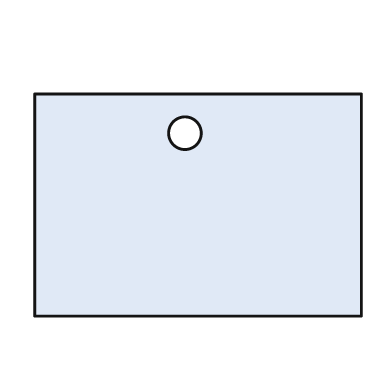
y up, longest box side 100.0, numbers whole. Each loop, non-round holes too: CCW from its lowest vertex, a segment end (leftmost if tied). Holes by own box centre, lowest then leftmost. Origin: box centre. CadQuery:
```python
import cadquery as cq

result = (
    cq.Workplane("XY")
    .moveTo(-50.0, -34.0)
    .lineTo(50.0, -34.0)
    .lineTo(50.0, 34.0)
    .lineTo(-50.0, 34.0)
    .close()
    .moveTo(-4.0, 22.0)
    .circle(5.0)
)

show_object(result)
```